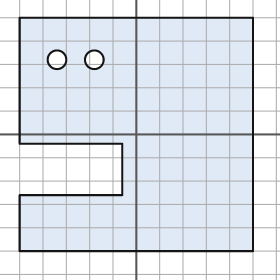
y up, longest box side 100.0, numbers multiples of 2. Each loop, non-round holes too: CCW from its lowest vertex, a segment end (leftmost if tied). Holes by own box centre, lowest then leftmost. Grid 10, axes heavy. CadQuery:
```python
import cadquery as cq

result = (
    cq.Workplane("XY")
    .moveTo(-50.0, -50.0)
    .lineTo(50.0, -50.0)
    .lineTo(50.0, 50.0)
    .lineTo(-50.0, 50.0)
    .lineTo(-50.0, -4.0)
    .lineTo(-6.0, -4.0)
    .lineTo(-6.0, -26.0)
    .lineTo(-50.0, -26.0)
    .close()
    .moveTo(-34.0, 32.0)
    .circle(4.0)
    .moveTo(-18.0, 32.0)
    .circle(4.0)
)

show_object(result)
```